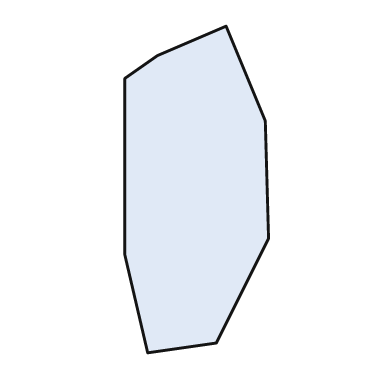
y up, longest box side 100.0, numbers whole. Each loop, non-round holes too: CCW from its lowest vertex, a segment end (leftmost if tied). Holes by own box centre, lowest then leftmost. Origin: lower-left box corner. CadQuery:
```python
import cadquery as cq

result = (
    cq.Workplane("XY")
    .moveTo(7.0, 0.0)
    .lineTo(28.0, 3.0)
    .lineTo(44.0, 35.0)
    .lineTo(43.0, 71.0)
    .lineTo(31.0, 100.0)
    .lineTo(10.0, 91.0)
    .lineTo(0.0, 84.0)
    .lineTo(0.0, 30.0)
    .close()
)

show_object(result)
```